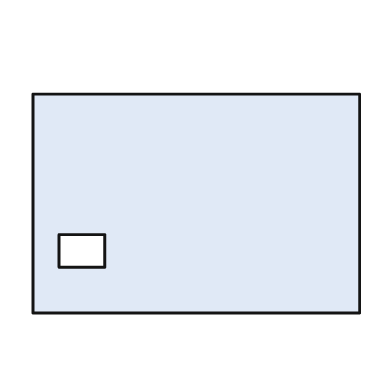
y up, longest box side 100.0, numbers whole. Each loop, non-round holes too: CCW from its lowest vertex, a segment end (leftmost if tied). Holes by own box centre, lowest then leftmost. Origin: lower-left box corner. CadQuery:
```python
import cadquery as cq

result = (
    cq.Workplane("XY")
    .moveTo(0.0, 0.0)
    .lineTo(100.0, 0.0)
    .lineTo(100.0, 67.0)
    .lineTo(0.0, 67.0)
    .close()
    .moveTo(8.0, 14.0)
    .lineTo(22.0, 14.0)
    .lineTo(22.0, 24.0)
    .lineTo(8.0, 24.0)
    .close()
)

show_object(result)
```